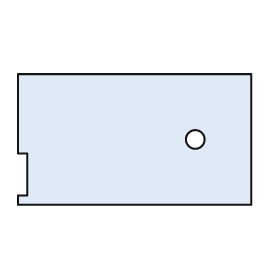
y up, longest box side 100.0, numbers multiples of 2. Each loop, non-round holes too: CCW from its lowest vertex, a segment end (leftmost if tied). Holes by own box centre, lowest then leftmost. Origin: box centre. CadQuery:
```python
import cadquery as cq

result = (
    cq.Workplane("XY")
    .moveTo(-50.0, -28.0)
    .lineTo(50.0, -28.0)
    .lineTo(50.0, 28.0)
    .lineTo(-50.0, 28.0)
    .lineTo(-50.0, -6.0)
    .lineTo(-46.0, -6.0)
    .lineTo(-46.0, -24.0)
    .lineTo(-50.0, -24.0)
    .close()
    .moveTo(26.0, 0.0)
    .circle(4.0)
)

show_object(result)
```